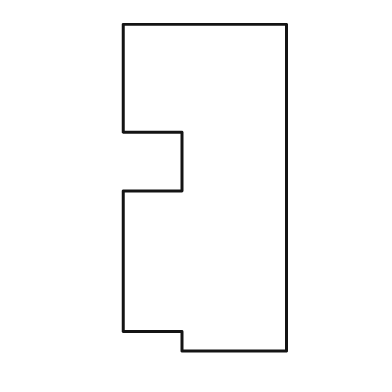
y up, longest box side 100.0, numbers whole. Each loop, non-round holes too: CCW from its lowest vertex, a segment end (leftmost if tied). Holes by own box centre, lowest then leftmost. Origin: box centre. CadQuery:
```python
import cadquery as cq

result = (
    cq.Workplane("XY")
    .moveTo(-7.0, -50.0)
    .lineTo(25.0, -50.0)
    .lineTo(25.0, 50.0)
    .lineTo(-25.0, 50.0)
    .lineTo(-25.0, 17.0)
    .lineTo(-7.0, 17.0)
    .lineTo(-7.0, -1.0)
    .lineTo(-25.0, -1.0)
    .lineTo(-25.0, -44.0)
    .lineTo(-7.0, -44.0)
    .close()
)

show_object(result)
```